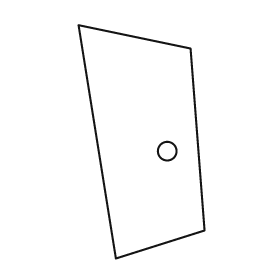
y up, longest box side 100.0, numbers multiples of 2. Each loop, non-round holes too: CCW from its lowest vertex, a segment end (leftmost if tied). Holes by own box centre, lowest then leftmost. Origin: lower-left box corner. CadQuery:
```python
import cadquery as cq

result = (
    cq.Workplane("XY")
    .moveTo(16.0, 0.0)
    .lineTo(54.0, 12.0)
    .lineTo(48.0, 90.0)
    .lineTo(0.0, 100.0)
    .close()
    .moveTo(38.0, 46.0)
    .circle(4.0)
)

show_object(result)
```